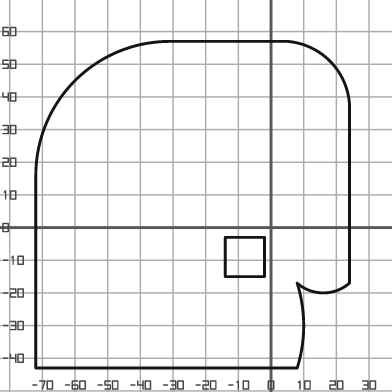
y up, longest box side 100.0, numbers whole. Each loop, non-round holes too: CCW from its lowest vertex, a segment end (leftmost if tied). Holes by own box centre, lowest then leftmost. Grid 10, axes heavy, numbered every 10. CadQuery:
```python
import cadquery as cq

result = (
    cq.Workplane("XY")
    .moveTo(-72.0, -43.0)
    .lineTo(8.0, -43.0)
    .threePointArc((10.0, -30.0), (8.0, -17.0))
    .threePointArc((16.0, -20.0), (24.0, -17.0))
    .lineTo(24.0, 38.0)
    .threePointArc((18.0, 51.0), (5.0, 57.0))
    .lineTo(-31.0, 57.0)
    .threePointArc((-60.0, 45.0), (-72.0, 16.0))
    .close()
    .moveTo(-14.0, -15.0)
    .lineTo(-2.0, -15.0)
    .lineTo(-2.0, -3.0)
    .lineTo(-14.0, -3.0)
    .close()
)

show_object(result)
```